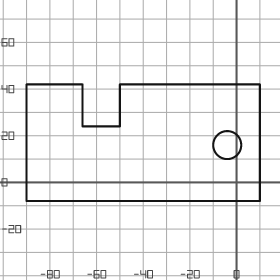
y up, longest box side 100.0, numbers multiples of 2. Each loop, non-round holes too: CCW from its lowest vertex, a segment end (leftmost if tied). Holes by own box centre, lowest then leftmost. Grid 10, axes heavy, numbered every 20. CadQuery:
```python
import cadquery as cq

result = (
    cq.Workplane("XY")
    .moveTo(-90.0, -8.0)
    .lineTo(10.0, -8.0)
    .lineTo(10.0, 42.0)
    .lineTo(-50.0, 42.0)
    .lineTo(-50.0, 24.0)
    .lineTo(-66.0, 24.0)
    .lineTo(-66.0, 42.0)
    .lineTo(-90.0, 42.0)
    .close()
    .moveTo(-4.0, 16.0)
    .circle(6.0)
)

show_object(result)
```